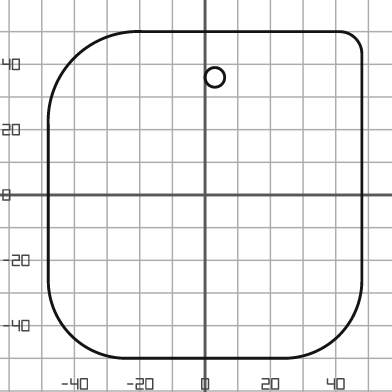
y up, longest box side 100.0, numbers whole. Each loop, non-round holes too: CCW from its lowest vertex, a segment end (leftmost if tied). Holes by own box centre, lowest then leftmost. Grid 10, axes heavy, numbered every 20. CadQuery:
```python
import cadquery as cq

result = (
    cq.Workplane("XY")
    .moveTo(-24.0, -50.0)
    .lineTo(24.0, -50.0)
    .threePointArc((41.0, -43.0), (48.0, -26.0))
    .lineTo(48.0, 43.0)
    .threePointArc((46.0, 48.0), (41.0, 50.0))
    .lineTo(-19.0, 50.0)
    .threePointArc((-40.0, 42.0), (-48.0, 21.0))
    .lineTo(-48.0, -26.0)
    .threePointArc((-41.0, -43.0), (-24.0, -50.0))
    .close()
    .moveTo(3.0, 36.0)
    .circle(3.0)
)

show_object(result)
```